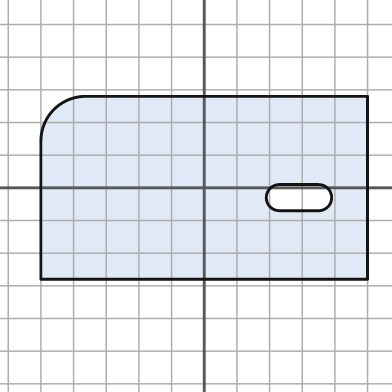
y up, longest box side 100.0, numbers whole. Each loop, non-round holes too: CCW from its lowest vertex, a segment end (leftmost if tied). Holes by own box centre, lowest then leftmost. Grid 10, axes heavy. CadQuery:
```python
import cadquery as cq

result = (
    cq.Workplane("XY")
    .moveTo(-50.0, -28.0)
    .lineTo(50.0, -28.0)
    .lineTo(50.0, 28.0)
    .lineTo(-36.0, 28.0)
    .threePointArc((-46.0, 24.0), (-50.0, 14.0))
    .close()
    .moveTo(23.0, -7.0)
    .lineTo(35.0, -7.0)
    .threePointArc((39.0, -3.0), (35.0, 1.0))
    .lineTo(23.0, 1.0)
    .threePointArc((19.0, -3.0), (23.0, -7.0))
    .close()
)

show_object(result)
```